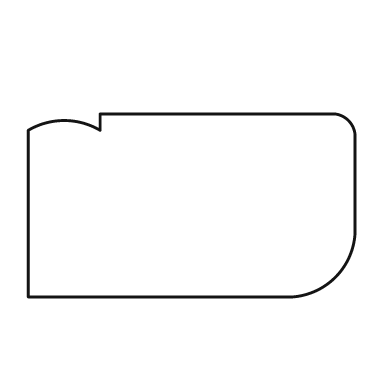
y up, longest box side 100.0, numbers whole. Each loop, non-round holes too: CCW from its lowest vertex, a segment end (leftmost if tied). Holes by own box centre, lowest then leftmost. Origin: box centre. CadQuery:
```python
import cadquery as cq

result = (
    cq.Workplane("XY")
    .moveTo(-50.0, -28.0)
    .lineTo(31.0, -28.0)
    .threePointArc((44.0, -22.0), (50.0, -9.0))
    .lineTo(50.0, 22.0)
    .threePointArc((48.0, 26.0), (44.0, 28.0))
    .lineTo(-28.0, 28.0)
    .lineTo(-28.0, 23.0)
    .threePointArc((-39.0, 26.0), (-50.0, 23.0))
    .close()
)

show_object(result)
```